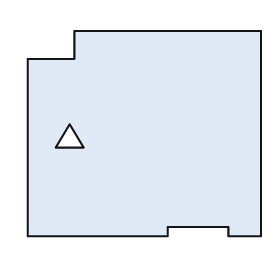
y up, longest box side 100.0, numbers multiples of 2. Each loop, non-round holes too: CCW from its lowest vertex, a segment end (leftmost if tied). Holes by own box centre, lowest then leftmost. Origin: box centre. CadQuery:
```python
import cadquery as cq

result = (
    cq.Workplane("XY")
    .moveTo(-50.0, -44.0)
    .lineTo(10.0, -44.0)
    .lineTo(10.0, -40.0)
    .lineTo(36.0, -40.0)
    .lineTo(36.0, -44.0)
    .lineTo(50.0, -44.0)
    .lineTo(50.0, 44.0)
    .lineTo(-30.0, 44.0)
    .lineTo(-30.0, 32.0)
    .lineTo(-50.0, 32.0)
    .close()
    .moveTo(-38.0, -6.0)
    .lineTo(-26.0, -6.0)
    .lineTo(-32.0, 4.0)
    .close()
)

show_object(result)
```